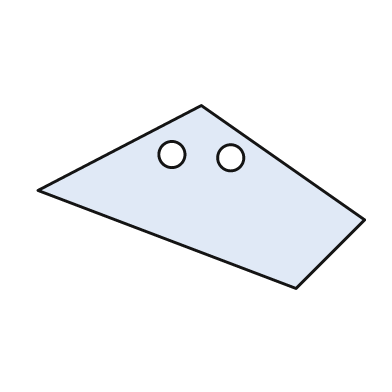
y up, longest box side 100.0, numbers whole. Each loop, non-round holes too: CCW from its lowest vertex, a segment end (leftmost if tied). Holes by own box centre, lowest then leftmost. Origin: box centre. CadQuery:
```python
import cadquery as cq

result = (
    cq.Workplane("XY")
    .moveTo(29.0, -28.0)
    .lineTo(50.0, -7.0)
    .lineTo(0.0, 28.0)
    .lineTo(-50.0, 2.0)
    .close()
    .moveTo(9.0, 12.0)
    .circle(4.0)
    .moveTo(-9.0, 13.0)
    .circle(4.0)
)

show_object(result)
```